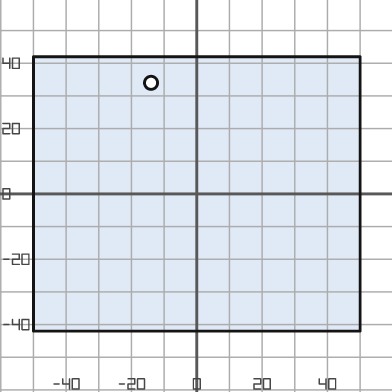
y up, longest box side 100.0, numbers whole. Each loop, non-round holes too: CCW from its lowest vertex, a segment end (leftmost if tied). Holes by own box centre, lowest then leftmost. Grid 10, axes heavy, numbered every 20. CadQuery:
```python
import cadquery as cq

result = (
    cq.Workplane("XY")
    .moveTo(-50.0, -42.0)
    .lineTo(50.0, -42.0)
    .lineTo(50.0, 42.0)
    .lineTo(-50.0, 42.0)
    .close()
    .moveTo(-14.0, 34.0)
    .circle(2.0)
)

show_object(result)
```